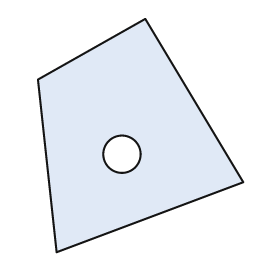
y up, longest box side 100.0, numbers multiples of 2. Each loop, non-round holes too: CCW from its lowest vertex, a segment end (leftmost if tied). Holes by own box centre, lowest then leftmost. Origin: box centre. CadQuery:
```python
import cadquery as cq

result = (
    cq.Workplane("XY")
    .moveTo(-36.0, -50.0)
    .lineTo(44.0, -20.0)
    .lineTo(2.0, 50.0)
    .lineTo(-44.0, 24.0)
    .close()
    .moveTo(-8.0, -8.0)
    .circle(8.0)
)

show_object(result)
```